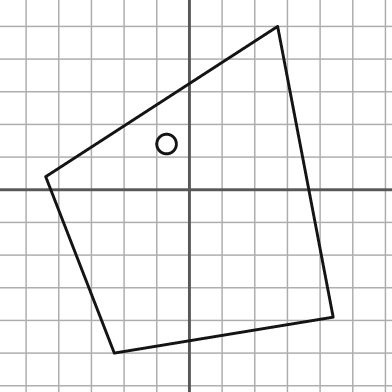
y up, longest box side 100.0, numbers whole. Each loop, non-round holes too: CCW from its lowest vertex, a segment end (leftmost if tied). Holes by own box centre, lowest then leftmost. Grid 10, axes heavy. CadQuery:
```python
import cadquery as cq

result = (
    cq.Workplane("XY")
    .moveTo(-23.0, -50.0)
    .lineTo(44.0, -39.0)
    .lineTo(27.0, 50.0)
    .lineTo(-44.0, 4.0)
    .close()
    .moveTo(-7.0, 14.0)
    .circle(3.0)
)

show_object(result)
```